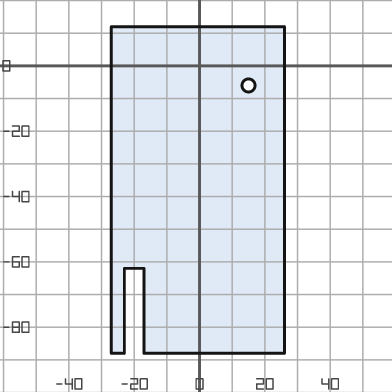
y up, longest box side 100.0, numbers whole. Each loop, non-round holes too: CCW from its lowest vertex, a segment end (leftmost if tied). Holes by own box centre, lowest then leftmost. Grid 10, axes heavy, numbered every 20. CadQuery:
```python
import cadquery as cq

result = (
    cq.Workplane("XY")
    .moveTo(-27.0, -88.0)
    .lineTo(-23.0, -88.0)
    .lineTo(-23.0, -62.0)
    .lineTo(-17.0, -62.0)
    .lineTo(-17.0, -88.0)
    .lineTo(26.0, -88.0)
    .lineTo(26.0, 12.0)
    .lineTo(-27.0, 12.0)
    .close()
    .moveTo(15.0, -6.0)
    .circle(2.0)
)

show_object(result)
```